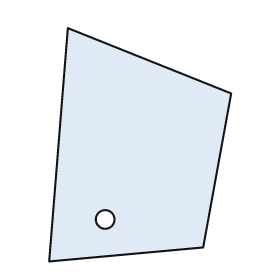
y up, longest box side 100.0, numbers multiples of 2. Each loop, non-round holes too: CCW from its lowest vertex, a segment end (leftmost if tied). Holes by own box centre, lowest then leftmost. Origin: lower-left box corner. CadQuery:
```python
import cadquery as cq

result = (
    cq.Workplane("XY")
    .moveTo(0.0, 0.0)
    .lineTo(66.0, 6.0)
    .lineTo(78.0, 72.0)
    .lineTo(8.0, 100.0)
    .close()
    .moveTo(24.0, 18.0)
    .circle(4.0)
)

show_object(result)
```